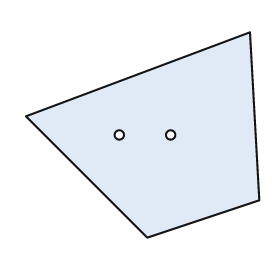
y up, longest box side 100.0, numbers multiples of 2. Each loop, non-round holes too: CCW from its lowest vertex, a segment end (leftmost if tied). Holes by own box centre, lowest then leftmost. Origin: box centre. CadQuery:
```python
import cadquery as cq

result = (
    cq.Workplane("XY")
    .moveTo(2.0, -44.0)
    .lineTo(50.0, -28.0)
    .lineTo(46.0, 44.0)
    .lineTo(-50.0, 8.0)
    .close()
    .moveTo(-10.0, 0.0)
    .circle(2.0)
    .moveTo(12.0, 0.0)
    .circle(2.0)
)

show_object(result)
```